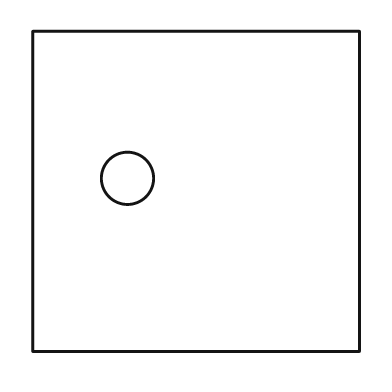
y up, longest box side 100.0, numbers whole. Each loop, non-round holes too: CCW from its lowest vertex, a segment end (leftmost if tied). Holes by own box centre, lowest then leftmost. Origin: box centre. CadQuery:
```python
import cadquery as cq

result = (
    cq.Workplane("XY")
    .moveTo(-50.0, -49.0)
    .lineTo(50.0, -49.0)
    .lineTo(50.0, 49.0)
    .lineTo(-50.0, 49.0)
    .close()
    .moveTo(-21.0, 4.0)
    .circle(8.0)
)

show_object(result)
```